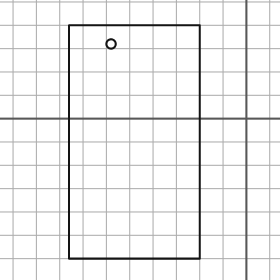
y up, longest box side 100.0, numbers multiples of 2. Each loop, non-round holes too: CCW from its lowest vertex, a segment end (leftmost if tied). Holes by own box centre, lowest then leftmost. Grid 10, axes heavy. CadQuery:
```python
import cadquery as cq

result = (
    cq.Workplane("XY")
    .moveTo(-76.0, -60.0)
    .lineTo(-20.0, -60.0)
    .lineTo(-20.0, 40.0)
    .lineTo(-76.0, 40.0)
    .close()
    .moveTo(-58.0, 32.0)
    .circle(2.0)
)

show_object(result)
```